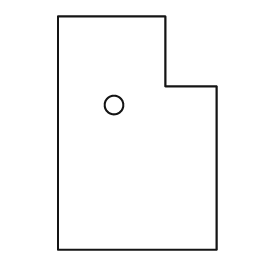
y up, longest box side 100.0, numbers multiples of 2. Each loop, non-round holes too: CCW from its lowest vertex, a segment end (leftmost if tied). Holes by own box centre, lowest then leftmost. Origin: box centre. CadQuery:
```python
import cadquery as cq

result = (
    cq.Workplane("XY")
    .moveTo(-34.0, -50.0)
    .lineTo(34.0, -50.0)
    .lineTo(34.0, 20.0)
    .lineTo(12.0, 20.0)
    .lineTo(12.0, 50.0)
    .lineTo(-34.0, 50.0)
    .close()
    .moveTo(-10.0, 12.0)
    .circle(4.0)
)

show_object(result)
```